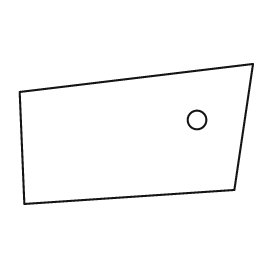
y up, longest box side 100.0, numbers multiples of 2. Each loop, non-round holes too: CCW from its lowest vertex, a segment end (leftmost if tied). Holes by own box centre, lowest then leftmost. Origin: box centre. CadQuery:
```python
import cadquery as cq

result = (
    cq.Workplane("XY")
    .moveTo(-48.0, -30.0)
    .lineTo(42.0, -24.0)
    .lineTo(50.0, 30.0)
    .lineTo(-50.0, 18.0)
    .close()
    .moveTo(26.0, 6.0)
    .circle(4.0)
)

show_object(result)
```